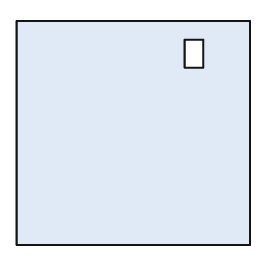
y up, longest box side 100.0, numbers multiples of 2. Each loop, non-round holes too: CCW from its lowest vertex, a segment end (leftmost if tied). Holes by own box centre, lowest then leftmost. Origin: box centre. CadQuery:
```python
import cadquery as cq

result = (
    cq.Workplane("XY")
    .moveTo(-50.0, -48.0)
    .lineTo(50.0, -48.0)
    .lineTo(50.0, 48.0)
    .lineTo(-50.0, 48.0)
    .close()
    .moveTo(22.0, 28.0)
    .lineTo(30.0, 28.0)
    .lineTo(30.0, 40.0)
    .lineTo(22.0, 40.0)
    .close()
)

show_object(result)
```